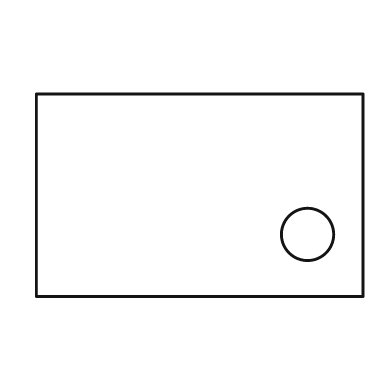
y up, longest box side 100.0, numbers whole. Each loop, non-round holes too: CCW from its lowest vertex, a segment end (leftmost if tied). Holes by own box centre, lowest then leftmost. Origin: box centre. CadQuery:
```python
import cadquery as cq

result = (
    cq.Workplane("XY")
    .moveTo(-50.0, -31.0)
    .lineTo(50.0, -31.0)
    .lineTo(50.0, 31.0)
    .lineTo(-50.0, 31.0)
    .close()
    .moveTo(33.0, -12.0)
    .circle(8.0)
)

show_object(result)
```